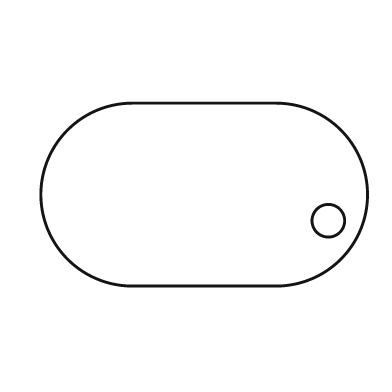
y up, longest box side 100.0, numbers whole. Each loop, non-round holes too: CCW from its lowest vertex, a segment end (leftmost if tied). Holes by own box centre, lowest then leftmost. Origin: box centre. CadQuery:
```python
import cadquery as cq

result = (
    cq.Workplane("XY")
    .moveTo(-22.0, -28.0)
    .lineTo(22.0, -28.0)
    .threePointArc((50.0, 0.0), (22.0, 28.0))
    .lineTo(-22.0, 28.0)
    .threePointArc((-50.0, 0.0), (-22.0, -28.0))
    .close()
    .moveTo(38.0, -8.0)
    .circle(5.0)
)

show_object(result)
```